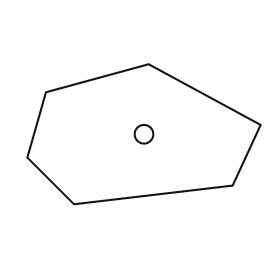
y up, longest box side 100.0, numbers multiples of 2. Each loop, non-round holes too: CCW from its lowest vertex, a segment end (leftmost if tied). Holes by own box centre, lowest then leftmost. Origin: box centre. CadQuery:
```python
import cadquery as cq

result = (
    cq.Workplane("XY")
    .moveTo(-30.0, -30.0)
    .lineTo(38.0, -22.0)
    .lineTo(50.0, 4.0)
    .lineTo(2.0, 30.0)
    .lineTo(-42.0, 18.0)
    .lineTo(-50.0, -10.0)
    .close()
    .moveTo(0.0, 0.0)
    .circle(4.0)
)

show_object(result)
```